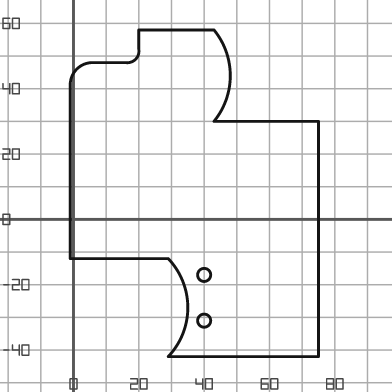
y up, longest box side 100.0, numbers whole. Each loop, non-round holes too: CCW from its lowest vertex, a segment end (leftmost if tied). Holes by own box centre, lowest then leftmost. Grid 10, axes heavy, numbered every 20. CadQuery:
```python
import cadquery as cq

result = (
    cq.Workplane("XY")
    .moveTo(29.0, -42.0)
    .lineTo(75.0, -42.0)
    .lineTo(75.0, 30.0)
    .lineTo(43.0, 30.0)
    .threePointArc((48.0, 44.0), (43.0, 58.0))
    .lineTo(20.0, 58.0)
    .lineTo(20.0, 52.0)
    .threePointArc((19.0, 49.0), (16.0, 48.0))
    .lineTo(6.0, 48.0)
    .threePointArc((1.0, 46.0), (-1.0, 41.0))
    .lineTo(-1.0, -12.0)
    .lineTo(29.0, -12.0)
    .threePointArc((35.0, -27.0), (29.0, -42.0))
    .close()
    .moveTo(40.0, -31.0)
    .circle(2.0)
    .moveTo(40.0, -17.0)
    .circle(2.0)
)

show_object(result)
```